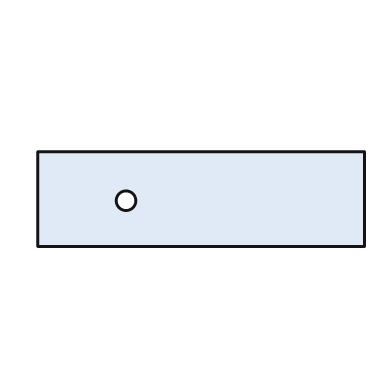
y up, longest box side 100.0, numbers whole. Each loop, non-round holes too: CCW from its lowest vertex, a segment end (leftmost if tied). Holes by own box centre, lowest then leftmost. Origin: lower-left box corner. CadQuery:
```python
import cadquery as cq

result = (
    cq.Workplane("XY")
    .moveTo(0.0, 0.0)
    .lineTo(100.0, 0.0)
    .lineTo(100.0, 29.0)
    .lineTo(0.0, 29.0)
    .close()
    .moveTo(27.0, 14.0)
    .circle(3.0)
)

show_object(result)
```